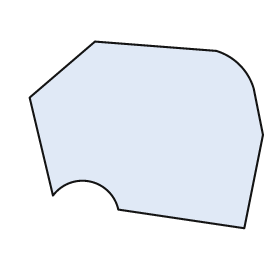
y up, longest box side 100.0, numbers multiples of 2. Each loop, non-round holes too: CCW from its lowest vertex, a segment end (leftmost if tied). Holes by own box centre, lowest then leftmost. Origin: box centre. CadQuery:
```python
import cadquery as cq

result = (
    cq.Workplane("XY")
    .moveTo(42.0, -40.0)
    .lineTo(50.0, 0.0)
    .lineTo(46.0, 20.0)
    .threePointArc((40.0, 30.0), (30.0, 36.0))
    .lineTo(-22.0, 40.0)
    .lineTo(-50.0, 16.0)
    .lineTo(-40.0, -26.0)
    .threePointArc((-24.0, -20.0), (-12.0, -32.0))
    .close()
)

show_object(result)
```